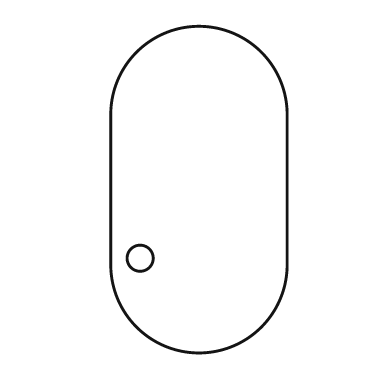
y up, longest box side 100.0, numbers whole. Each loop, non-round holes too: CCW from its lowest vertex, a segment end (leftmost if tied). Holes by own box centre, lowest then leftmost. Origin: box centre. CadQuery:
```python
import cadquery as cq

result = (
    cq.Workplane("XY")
    .moveTo(-27.0, -23.0)
    .threePointArc((0.0, -50.0), (27.0, -23.0))
    .lineTo(27.0, 23.0)
    .threePointArc((0.0, 50.0), (-27.0, 23.0))
    .close()
    .moveTo(-18.0, -21.0)
    .circle(4.0)
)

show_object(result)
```